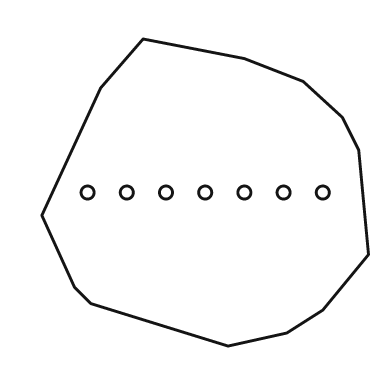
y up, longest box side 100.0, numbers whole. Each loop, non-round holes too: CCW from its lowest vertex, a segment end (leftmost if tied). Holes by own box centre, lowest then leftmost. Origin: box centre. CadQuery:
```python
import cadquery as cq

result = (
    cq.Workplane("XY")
    .moveTo(7.0, -47.0)
    .lineTo(25.0, -43.0)
    .lineTo(36.0, -36.0)
    .lineTo(50.0, -19.0)
    .lineTo(47.0, 13.0)
    .lineTo(42.0, 23.0)
    .lineTo(30.0, 34.0)
    .lineTo(12.0, 41.0)
    .lineTo(-19.0, 47.0)
    .lineTo(-32.0, 32.0)
    .lineTo(-50.0, -7.0)
    .lineTo(-40.0, -29.0)
    .lineTo(-35.0, -34.0)
    .close()
    .moveTo(-36.0, 0.0)
    .circle(2.0)
    .moveTo(-24.0, 0.0)
    .circle(2.0)
    .moveTo(-12.0, 0.0)
    .circle(2.0)
    .moveTo(0.0, 0.0)
    .circle(2.0)
    .moveTo(12.0, 0.0)
    .circle(2.0)
    .moveTo(24.0, 0.0)
    .circle(2.0)
    .moveTo(36.0, 0.0)
    .circle(2.0)
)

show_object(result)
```